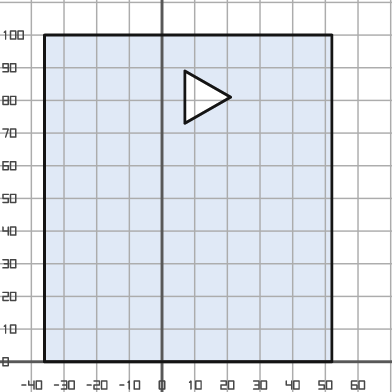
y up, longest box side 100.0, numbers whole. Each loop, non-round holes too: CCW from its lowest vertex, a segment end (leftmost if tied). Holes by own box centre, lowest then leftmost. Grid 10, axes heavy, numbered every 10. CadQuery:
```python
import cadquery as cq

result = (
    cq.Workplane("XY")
    .moveTo(-36.0, 0.0)
    .lineTo(52.0, 0.0)
    .lineTo(52.0, 100.0)
    .lineTo(-36.0, 100.0)
    .close()
    .moveTo(7.0, 73.0)
    .lineTo(21.0, 81.0)
    .lineTo(7.0, 89.0)
    .close()
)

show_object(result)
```